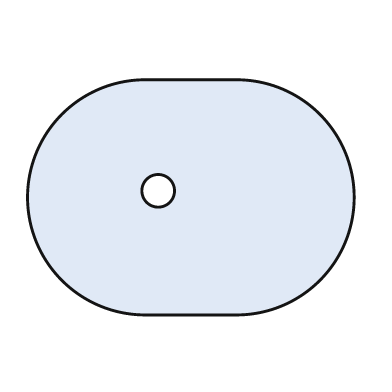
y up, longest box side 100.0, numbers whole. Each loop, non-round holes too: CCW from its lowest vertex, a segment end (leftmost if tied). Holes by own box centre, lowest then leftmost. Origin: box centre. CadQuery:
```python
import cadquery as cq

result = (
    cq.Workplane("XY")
    .moveTo(-14.0, -36.0)
    .lineTo(14.0, -36.0)
    .threePointArc((50.0, 0.0), (14.0, 36.0))
    .lineTo(-14.0, 36.0)
    .threePointArc((-50.0, 0.0), (-14.0, -36.0))
    .close()
    .moveTo(-10.0, 2.0)
    .circle(5.0)
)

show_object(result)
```